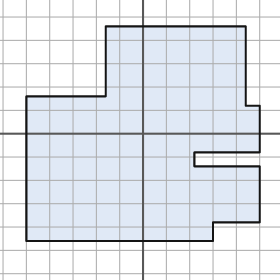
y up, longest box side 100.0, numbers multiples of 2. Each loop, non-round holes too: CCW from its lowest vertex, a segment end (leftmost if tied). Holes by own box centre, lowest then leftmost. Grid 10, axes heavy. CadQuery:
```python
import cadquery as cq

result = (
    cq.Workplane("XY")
    .moveTo(-50.0, -46.0)
    .lineTo(30.0, -46.0)
    .lineTo(30.0, -38.0)
    .lineTo(50.0, -38.0)
    .lineTo(50.0, -14.0)
    .lineTo(22.0, -14.0)
    .lineTo(22.0, -8.0)
    .lineTo(50.0, -8.0)
    .lineTo(50.0, 12.0)
    .lineTo(44.0, 12.0)
    .lineTo(44.0, 46.0)
    .lineTo(-16.0, 46.0)
    .lineTo(-16.0, 16.0)
    .lineTo(-50.0, 16.0)
    .close()
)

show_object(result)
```